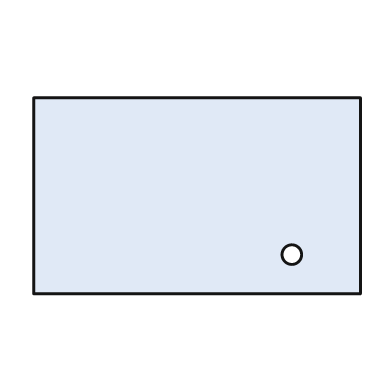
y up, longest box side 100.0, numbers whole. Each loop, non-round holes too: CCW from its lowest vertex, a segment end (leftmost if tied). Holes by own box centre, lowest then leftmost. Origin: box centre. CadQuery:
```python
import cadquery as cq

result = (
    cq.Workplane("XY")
    .moveTo(-50.0, -30.0)
    .lineTo(50.0, -30.0)
    .lineTo(50.0, 30.0)
    .lineTo(-50.0, 30.0)
    .close()
    .moveTo(29.0, -18.0)
    .circle(3.0)
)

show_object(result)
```